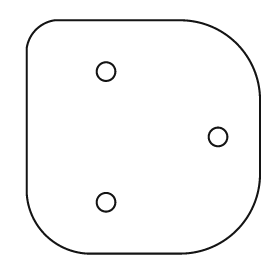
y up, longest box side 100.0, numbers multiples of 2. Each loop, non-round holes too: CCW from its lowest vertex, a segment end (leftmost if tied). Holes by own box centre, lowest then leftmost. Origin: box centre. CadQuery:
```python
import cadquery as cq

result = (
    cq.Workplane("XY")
    .moveTo(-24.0, -50.0)
    .lineTo(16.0, -50.0)
    .threePointArc((40.0, -40.0), (50.0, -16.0))
    .lineTo(50.0, 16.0)
    .threePointArc((40.0, 40.0), (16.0, 50.0))
    .lineTo(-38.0, 50.0)
    .threePointArc((-46.0, 46.0), (-50.0, 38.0))
    .lineTo(-50.0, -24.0)
    .threePointArc((-42.0, -42.0), (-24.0, -50.0))
    .close()
    .moveTo(-16.0, -28.0)
    .circle(4.0)
    .moveTo(32.0, 0.0)
    .circle(4.0)
    .moveTo(-16.0, 28.0)
    .circle(4.0)
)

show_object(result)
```